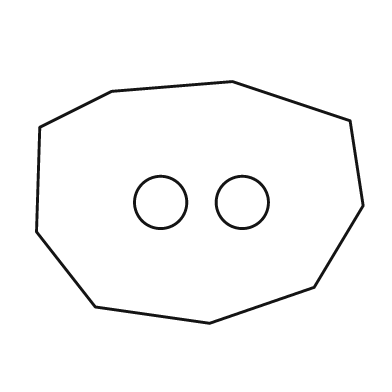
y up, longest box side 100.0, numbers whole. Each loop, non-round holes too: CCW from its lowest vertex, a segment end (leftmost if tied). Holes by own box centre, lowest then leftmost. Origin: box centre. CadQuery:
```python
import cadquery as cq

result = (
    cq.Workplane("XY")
    .moveTo(3.0, -37.0)
    .lineTo(35.0, -26.0)
    .lineTo(50.0, -1.0)
    .lineTo(46.0, 25.0)
    .lineTo(10.0, 37.0)
    .lineTo(-27.0, 34.0)
    .lineTo(-49.0, 23.0)
    .lineTo(-50.0, -9.0)
    .lineTo(-32.0, -32.0)
    .close()
    .moveTo(-12.0, 0.0)
    .circle(8.0)
    .moveTo(13.0, 0.0)
    .circle(8.0)
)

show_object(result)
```